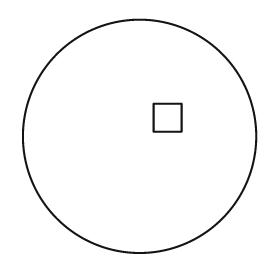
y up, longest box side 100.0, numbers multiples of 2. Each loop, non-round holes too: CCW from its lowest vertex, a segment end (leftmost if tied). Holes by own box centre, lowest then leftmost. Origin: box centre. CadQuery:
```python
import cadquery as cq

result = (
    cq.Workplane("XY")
    .moveTo(0.0, 0.0)
    .circle(50.0)
    .moveTo(6.0, 2.0)
    .lineTo(18.0, 2.0)
    .lineTo(18.0, 14.0)
    .lineTo(6.0, 14.0)
    .close()
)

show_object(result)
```